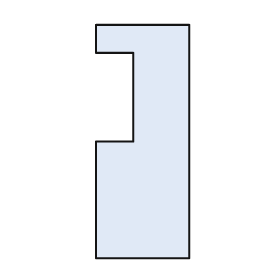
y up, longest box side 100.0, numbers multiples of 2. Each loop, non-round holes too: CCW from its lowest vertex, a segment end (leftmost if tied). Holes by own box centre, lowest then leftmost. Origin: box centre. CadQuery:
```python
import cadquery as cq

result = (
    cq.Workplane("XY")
    .moveTo(-20.0, -50.0)
    .lineTo(20.0, -50.0)
    .lineTo(20.0, 50.0)
    .lineTo(-20.0, 50.0)
    .lineTo(-20.0, 38.0)
    .lineTo(-4.0, 38.0)
    .lineTo(-4.0, 0.0)
    .lineTo(-20.0, 0.0)
    .close()
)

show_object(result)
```